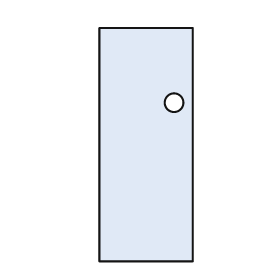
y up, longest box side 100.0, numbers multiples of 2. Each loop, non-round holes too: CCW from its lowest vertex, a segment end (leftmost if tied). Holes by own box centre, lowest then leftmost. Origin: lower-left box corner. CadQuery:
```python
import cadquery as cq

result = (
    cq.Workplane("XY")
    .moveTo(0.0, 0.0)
    .lineTo(40.0, 0.0)
    .lineTo(40.0, 100.0)
    .lineTo(0.0, 100.0)
    .close()
    .moveTo(32.0, 68.0)
    .circle(4.0)
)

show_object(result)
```